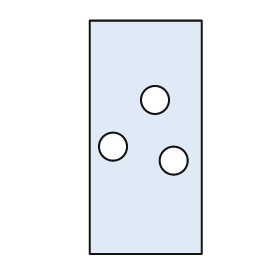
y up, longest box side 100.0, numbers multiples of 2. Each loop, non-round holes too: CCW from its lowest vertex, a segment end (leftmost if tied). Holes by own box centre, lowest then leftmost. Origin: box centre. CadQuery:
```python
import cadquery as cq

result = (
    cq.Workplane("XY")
    .moveTo(-24.0, -50.0)
    .lineTo(24.0, -50.0)
    .lineTo(24.0, 50.0)
    .lineTo(-24.0, 50.0)
    .close()
    .moveTo(12.0, -10.0)
    .circle(6.0)
    .moveTo(-14.0, -4.0)
    .circle(6.0)
    .moveTo(4.0, 16.0)
    .circle(6.0)
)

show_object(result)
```